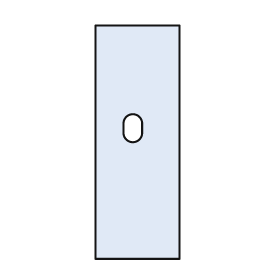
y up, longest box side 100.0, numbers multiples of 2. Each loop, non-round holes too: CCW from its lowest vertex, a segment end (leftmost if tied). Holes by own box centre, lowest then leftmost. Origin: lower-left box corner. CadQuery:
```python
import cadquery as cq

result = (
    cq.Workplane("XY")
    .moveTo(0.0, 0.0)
    .lineTo(36.0, 0.0)
    .lineTo(36.0, 100.0)
    .lineTo(0.0, 100.0)
    .close()
    .moveTo(12.0, 54.0)
    .threePointArc((16.0, 50.0), (20.0, 54.0))
    .lineTo(20.0, 58.0)
    .threePointArc((16.0, 62.0), (12.0, 58.0))
    .close()
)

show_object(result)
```